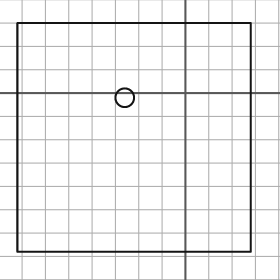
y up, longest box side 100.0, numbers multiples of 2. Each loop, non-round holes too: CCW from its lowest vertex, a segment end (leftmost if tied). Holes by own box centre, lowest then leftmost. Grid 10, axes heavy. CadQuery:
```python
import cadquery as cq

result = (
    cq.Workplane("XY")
    .moveTo(-72.0, -68.0)
    .lineTo(28.0, -68.0)
    .lineTo(28.0, 30.0)
    .lineTo(-72.0, 30.0)
    .close()
    .moveTo(-26.0, -2.0)
    .circle(4.0)
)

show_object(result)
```